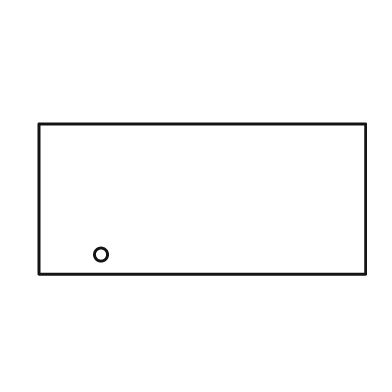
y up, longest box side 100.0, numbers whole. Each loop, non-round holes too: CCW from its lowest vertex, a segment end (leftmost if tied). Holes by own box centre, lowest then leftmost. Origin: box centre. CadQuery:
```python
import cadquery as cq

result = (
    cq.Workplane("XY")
    .moveTo(-50.0, -23.0)
    .lineTo(50.0, -23.0)
    .lineTo(50.0, 23.0)
    .lineTo(-50.0, 23.0)
    .close()
    .moveTo(-31.0, -17.0)
    .circle(2.0)
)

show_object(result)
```